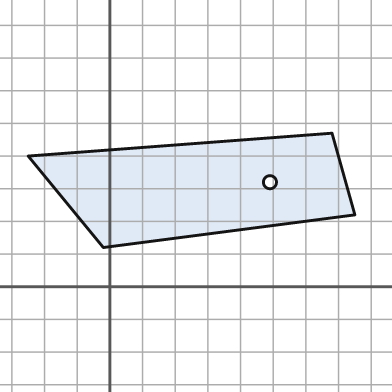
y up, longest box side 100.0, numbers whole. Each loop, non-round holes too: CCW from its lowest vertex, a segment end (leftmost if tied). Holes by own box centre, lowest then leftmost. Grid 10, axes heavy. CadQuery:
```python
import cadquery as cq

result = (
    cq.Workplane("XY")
    .moveTo(-2.0, 12.0)
    .lineTo(75.0, 22.0)
    .lineTo(68.0, 47.0)
    .lineTo(-25.0, 40.0)
    .close()
    .moveTo(49.0, 32.0)
    .circle(2.0)
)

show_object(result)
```